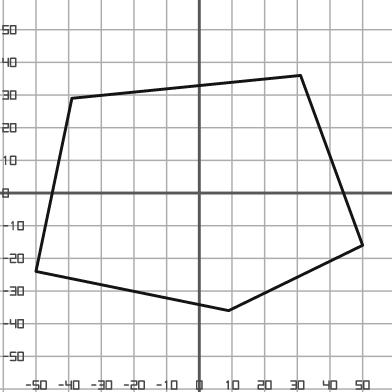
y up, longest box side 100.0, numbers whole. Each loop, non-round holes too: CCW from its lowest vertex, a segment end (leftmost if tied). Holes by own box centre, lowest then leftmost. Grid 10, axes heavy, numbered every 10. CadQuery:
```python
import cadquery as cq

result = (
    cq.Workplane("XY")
    .moveTo(9.0, -36.0)
    .lineTo(50.0, -16.0)
    .lineTo(31.0, 36.0)
    .lineTo(-39.0, 29.0)
    .lineTo(-50.0, -24.0)
    .close()
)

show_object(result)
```